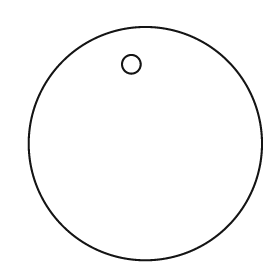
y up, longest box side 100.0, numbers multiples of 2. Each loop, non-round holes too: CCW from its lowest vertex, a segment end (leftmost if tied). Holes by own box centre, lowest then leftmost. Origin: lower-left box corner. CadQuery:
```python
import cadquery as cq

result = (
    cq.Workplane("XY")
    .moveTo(50.0, 50.0)
    .circle(50.0)
    .moveTo(44.0, 84.0)
    .circle(4.0)
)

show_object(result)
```